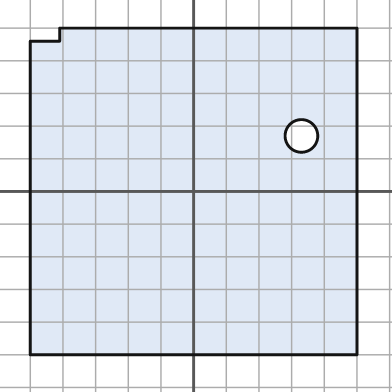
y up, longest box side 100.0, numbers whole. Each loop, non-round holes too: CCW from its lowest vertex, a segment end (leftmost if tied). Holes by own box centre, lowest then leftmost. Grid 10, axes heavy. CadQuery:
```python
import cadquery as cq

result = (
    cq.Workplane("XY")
    .moveTo(-50.0, -50.0)
    .lineTo(50.0, -50.0)
    .lineTo(50.0, 50.0)
    .lineTo(-41.0, 50.0)
    .lineTo(-41.0, 46.0)
    .lineTo(-50.0, 46.0)
    .close()
    .moveTo(33.0, 17.0)
    .circle(5.0)
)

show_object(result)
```